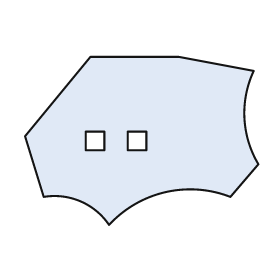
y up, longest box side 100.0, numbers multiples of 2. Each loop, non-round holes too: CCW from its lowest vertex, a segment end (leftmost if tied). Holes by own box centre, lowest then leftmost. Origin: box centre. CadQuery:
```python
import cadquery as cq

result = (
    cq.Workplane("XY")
    .moveTo(-14.0, -36.0)
    .threePointArc((10.0, -22.0), (38.0, -24.0))
    .lineTo(50.0, -10.0)
    .threePointArc((44.0, 10.0), (48.0, 30.0))
    .lineTo(16.0, 36.0)
    .lineTo(-22.0, 36.0)
    .lineTo(-50.0, 2.0)
    .lineTo(-42.0, -24.0)
    .threePointArc((-26.0, -26.0), (-14.0, -36.0))
    .close()
    .moveTo(-24.0, -4.0)
    .lineTo(-16.0, -4.0)
    .lineTo(-16.0, 4.0)
    .lineTo(-24.0, 4.0)
    .close()
    .moveTo(-6.0, -4.0)
    .lineTo(2.0, -4.0)
    .lineTo(2.0, 4.0)
    .lineTo(-6.0, 4.0)
    .close()
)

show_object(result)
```